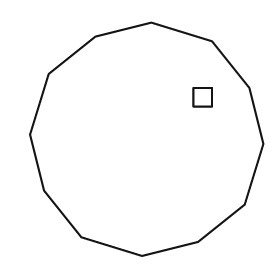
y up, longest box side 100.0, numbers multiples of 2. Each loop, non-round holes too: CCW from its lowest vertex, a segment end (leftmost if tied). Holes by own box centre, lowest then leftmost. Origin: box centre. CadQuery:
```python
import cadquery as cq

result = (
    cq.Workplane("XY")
    .moveTo(-2.0, -50.0)
    .lineTo(22.0, -44.0)
    .lineTo(42.0, -28.0)
    .lineTo(50.0, -2.0)
    .lineTo(44.0, 22.0)
    .lineTo(28.0, 42.0)
    .lineTo(2.0, 50.0)
    .lineTo(-22.0, 44.0)
    .lineTo(-42.0, 28.0)
    .lineTo(-50.0, 2.0)
    .lineTo(-44.0, -22.0)
    .lineTo(-28.0, -42.0)
    .close()
    .moveTo(20.0, 14.0)
    .lineTo(28.0, 14.0)
    .lineTo(28.0, 22.0)
    .lineTo(20.0, 22.0)
    .close()
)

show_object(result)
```